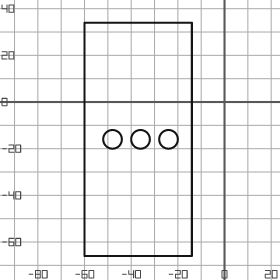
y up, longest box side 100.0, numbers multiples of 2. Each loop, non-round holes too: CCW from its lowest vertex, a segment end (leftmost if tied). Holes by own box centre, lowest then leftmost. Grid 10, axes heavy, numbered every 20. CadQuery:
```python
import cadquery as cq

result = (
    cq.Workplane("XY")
    .moveTo(-60.0, -66.0)
    .lineTo(-14.0, -66.0)
    .lineTo(-14.0, 34.0)
    .lineTo(-60.0, 34.0)
    .close()
    .moveTo(-48.0, -16.0)
    .circle(4.0)
    .moveTo(-36.0, -16.0)
    .circle(4.0)
    .moveTo(-24.0, -16.0)
    .circle(4.0)
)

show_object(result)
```